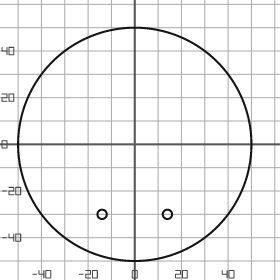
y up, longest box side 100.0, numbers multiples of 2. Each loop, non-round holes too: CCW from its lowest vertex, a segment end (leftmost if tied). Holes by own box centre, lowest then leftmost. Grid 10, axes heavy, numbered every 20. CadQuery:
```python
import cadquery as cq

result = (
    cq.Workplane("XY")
    .moveTo(0.0, 0.0)
    .circle(50.0)
    .moveTo(-14.0, -30.0)
    .circle(2.0)
    .moveTo(14.0, -30.0)
    .circle(2.0)
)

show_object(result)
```